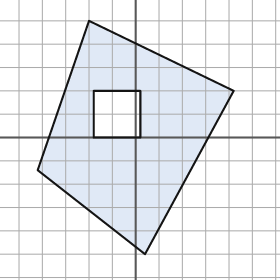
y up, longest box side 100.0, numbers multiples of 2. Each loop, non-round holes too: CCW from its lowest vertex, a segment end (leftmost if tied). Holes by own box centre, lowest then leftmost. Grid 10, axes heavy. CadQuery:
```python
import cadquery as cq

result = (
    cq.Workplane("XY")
    .moveTo(4.0, -50.0)
    .lineTo(42.0, 20.0)
    .lineTo(-20.0, 50.0)
    .lineTo(-42.0, -14.0)
    .close()
    .moveTo(-18.0, 0.0)
    .lineTo(2.0, 0.0)
    .lineTo(2.0, 20.0)
    .lineTo(-18.0, 20.0)
    .close()
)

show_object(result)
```